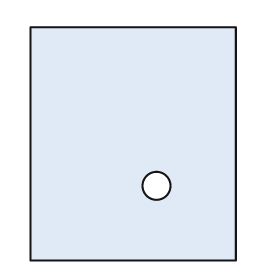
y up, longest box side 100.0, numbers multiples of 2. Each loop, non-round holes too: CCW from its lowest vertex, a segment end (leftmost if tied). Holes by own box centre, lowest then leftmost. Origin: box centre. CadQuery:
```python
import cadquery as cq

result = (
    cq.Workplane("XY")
    .moveTo(-44.0, -50.0)
    .lineTo(44.0, -50.0)
    .lineTo(44.0, 50.0)
    .lineTo(-44.0, 50.0)
    .close()
    .moveTo(10.0, -18.0)
    .circle(6.0)
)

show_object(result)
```